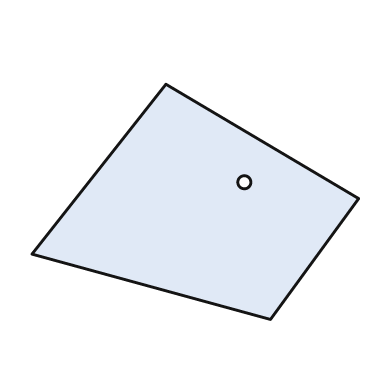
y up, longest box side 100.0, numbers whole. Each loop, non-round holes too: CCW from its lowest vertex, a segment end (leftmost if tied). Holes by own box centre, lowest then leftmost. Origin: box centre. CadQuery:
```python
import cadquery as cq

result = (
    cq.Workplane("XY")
    .moveTo(23.0, -36.0)
    .lineTo(50.0, 1.0)
    .lineTo(-9.0, 36.0)
    .lineTo(-50.0, -16.0)
    .close()
    .moveTo(15.0, 6.0)
    .circle(2.0)
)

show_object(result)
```